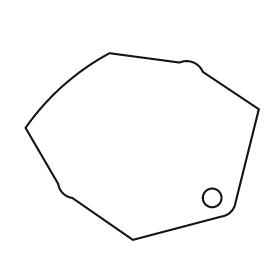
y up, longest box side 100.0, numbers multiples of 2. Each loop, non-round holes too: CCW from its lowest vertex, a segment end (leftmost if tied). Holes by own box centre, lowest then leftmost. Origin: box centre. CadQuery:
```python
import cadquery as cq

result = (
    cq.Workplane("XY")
    .moveTo(-4.0, -40.0)
    .lineTo(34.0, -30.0)
    .threePointArc((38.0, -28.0), (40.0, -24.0))
    .lineTo(50.0, 16.0)
    .lineTo(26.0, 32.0)
    .threePointArc((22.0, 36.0), (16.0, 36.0))
    .lineTo(-14.0, 40.0)
    .threePointArc((-34.0, 26.0), (-50.0, 8.0))
    .lineTo(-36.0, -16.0)
    .threePointArc((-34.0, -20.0), (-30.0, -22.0))
    .close()
    .moveTo(30.0, -22.0)
    .circle(4.0)
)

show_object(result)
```